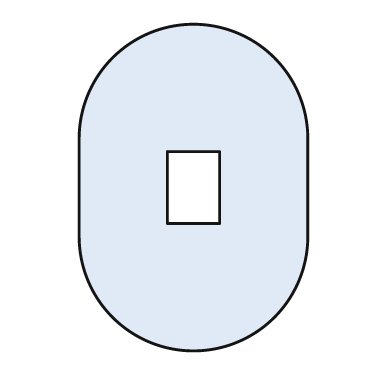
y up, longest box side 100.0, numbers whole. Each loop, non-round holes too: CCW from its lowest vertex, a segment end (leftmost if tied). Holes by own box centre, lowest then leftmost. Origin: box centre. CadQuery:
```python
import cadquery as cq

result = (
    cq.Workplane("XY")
    .moveTo(-35.0, -15.0)
    .threePointArc((0.0, -50.0), (35.0, -15.0))
    .lineTo(35.0, 15.0)
    .threePointArc((0.0, 50.0), (-35.0, 15.0))
    .close()
    .moveTo(-8.0, -11.0)
    .lineTo(8.0, -11.0)
    .lineTo(8.0, 11.0)
    .lineTo(-8.0, 11.0)
    .close()
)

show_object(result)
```